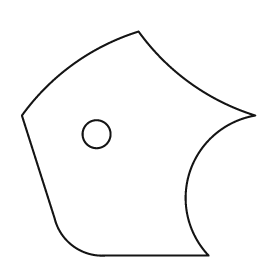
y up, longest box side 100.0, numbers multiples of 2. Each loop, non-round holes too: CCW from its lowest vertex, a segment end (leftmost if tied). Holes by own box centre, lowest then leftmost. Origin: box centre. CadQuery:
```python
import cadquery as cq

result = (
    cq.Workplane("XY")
    .moveTo(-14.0, -48.0)
    .lineTo(30.0, -48.0)
    .threePointArc((22.0, -12.0), (50.0, 12.0))
    .threePointArc((22.0, 26.0), (0.0, 48.0))
    .threePointArc((-28.0, 34.0), (-50.0, 12.0))
    .lineTo(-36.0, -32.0)
    .threePointArc((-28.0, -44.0), (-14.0, -48.0))
    .close()
    .moveTo(-18.0, 4.0)
    .circle(6.0)
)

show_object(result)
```